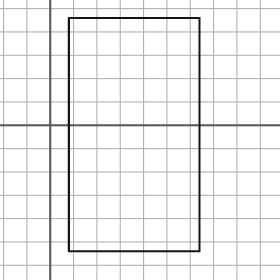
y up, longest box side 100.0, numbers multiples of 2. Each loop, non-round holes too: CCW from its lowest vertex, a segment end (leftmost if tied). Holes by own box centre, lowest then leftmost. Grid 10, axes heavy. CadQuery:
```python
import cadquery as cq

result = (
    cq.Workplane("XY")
    .moveTo(8.0, -54.0)
    .lineTo(64.0, -54.0)
    .lineTo(64.0, 46.0)
    .lineTo(8.0, 46.0)
    .close()
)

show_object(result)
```